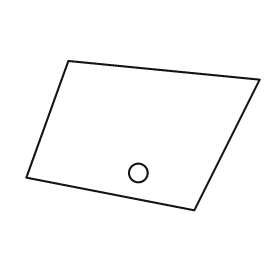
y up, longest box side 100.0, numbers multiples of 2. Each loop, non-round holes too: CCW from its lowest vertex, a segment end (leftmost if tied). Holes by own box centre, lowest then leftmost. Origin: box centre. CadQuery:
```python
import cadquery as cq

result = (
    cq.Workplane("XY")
    .moveTo(22.0, -32.0)
    .lineTo(50.0, 24.0)
    .lineTo(-32.0, 32.0)
    .lineTo(-50.0, -18.0)
    .close()
    .moveTo(-2.0, -16.0)
    .circle(4.0)
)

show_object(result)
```